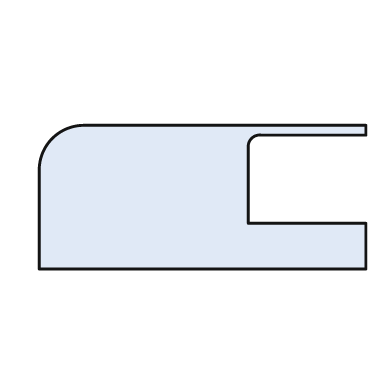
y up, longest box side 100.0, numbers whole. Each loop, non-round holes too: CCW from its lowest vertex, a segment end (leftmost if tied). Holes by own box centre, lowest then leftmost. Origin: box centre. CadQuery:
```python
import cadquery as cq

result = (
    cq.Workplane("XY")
    .moveTo(-50.0, -22.0)
    .lineTo(50.0, -22.0)
    .lineTo(50.0, -8.0)
    .lineTo(14.0, -8.0)
    .lineTo(14.0, 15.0)
    .threePointArc((15.0, 18.0), (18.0, 19.0))
    .lineTo(50.0, 19.0)
    .lineTo(50.0, 22.0)
    .lineTo(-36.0, 22.0)
    .threePointArc((-46.0, 18.0), (-50.0, 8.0))
    .close()
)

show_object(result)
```